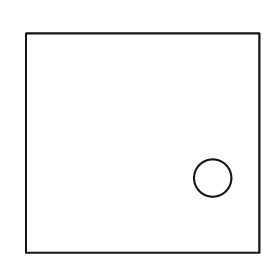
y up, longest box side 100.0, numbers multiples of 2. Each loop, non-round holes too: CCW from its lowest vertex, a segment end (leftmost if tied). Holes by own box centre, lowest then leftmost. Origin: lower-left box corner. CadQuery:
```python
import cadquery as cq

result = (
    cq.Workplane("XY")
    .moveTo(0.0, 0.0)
    .lineTo(100.0, 0.0)
    .lineTo(100.0, 94.0)
    .lineTo(0.0, 94.0)
    .close()
    .moveTo(80.0, 32.0)
    .circle(8.0)
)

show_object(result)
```